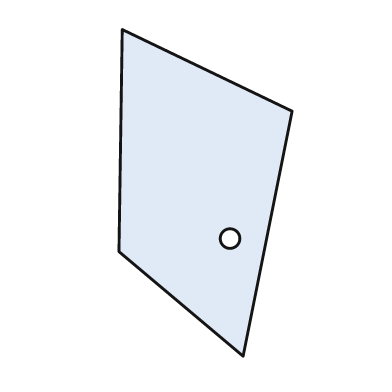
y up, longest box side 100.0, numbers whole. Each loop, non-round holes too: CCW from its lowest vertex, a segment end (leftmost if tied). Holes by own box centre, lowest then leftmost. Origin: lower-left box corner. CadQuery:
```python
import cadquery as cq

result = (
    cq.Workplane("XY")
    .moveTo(38.0, 0.0)
    .lineTo(53.0, 75.0)
    .lineTo(1.0, 100.0)
    .lineTo(0.0, 32.0)
    .close()
    .moveTo(34.0, 36.0)
    .circle(3.0)
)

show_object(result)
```